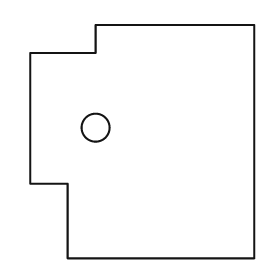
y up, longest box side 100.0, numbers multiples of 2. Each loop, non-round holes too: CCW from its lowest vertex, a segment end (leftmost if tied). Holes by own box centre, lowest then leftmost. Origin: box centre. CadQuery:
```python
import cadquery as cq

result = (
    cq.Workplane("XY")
    .moveTo(-32.0, -50.0)
    .lineTo(48.0, -50.0)
    .lineTo(48.0, 50.0)
    .lineTo(-20.0, 50.0)
    .lineTo(-20.0, 38.0)
    .lineTo(-48.0, 38.0)
    .lineTo(-48.0, -18.0)
    .lineTo(-32.0, -18.0)
    .close()
    .moveTo(-20.0, 6.0)
    .circle(6.0)
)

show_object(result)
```